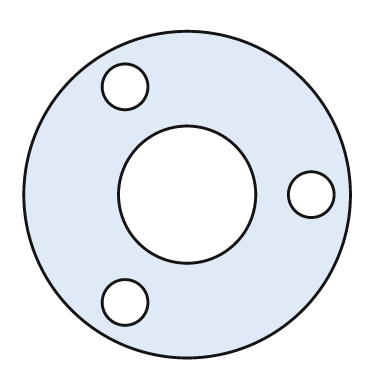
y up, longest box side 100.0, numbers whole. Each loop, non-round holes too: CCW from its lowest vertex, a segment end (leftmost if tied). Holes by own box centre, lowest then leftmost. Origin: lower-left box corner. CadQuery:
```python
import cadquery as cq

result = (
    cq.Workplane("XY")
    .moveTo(50.0, 50.0)
    .circle(50.0)
    .moveTo(31.0, 17.0)
    .circle(7.0)
    .moveTo(50.0, 50.0)
    .circle(21.0)
    .moveTo(88.0, 50.0)
    .circle(7.0)
    .moveTo(31.0, 83.0)
    .circle(7.0)
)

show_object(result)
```